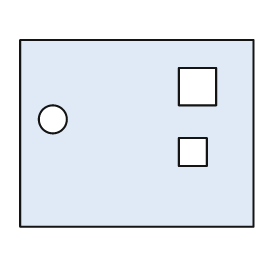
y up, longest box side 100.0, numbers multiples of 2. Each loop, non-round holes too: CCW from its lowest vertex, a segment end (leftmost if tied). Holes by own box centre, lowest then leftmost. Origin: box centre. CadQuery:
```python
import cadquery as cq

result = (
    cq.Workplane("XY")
    .moveTo(-50.0, -40.0)
    .lineTo(50.0, -40.0)
    .lineTo(50.0, 40.0)
    .lineTo(-50.0, 40.0)
    .close()
    .moveTo(18.0, -14.0)
    .lineTo(30.0, -14.0)
    .lineTo(30.0, -2.0)
    .lineTo(18.0, -2.0)
    .close()
    .moveTo(-36.0, 6.0)
    .circle(6.0)
    .moveTo(18.0, 12.0)
    .lineTo(34.0, 12.0)
    .lineTo(34.0, 28.0)
    .lineTo(18.0, 28.0)
    .close()
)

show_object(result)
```